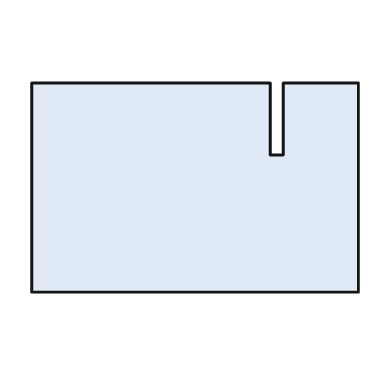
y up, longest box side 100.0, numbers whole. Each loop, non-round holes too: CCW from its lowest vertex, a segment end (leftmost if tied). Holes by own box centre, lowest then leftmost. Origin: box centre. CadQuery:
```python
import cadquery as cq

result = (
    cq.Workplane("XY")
    .moveTo(-50.0, -32.0)
    .lineTo(50.0, -32.0)
    .lineTo(50.0, 32.0)
    .lineTo(27.0, 32.0)
    .lineTo(27.0, 10.0)
    .lineTo(23.0, 10.0)
    .lineTo(23.0, 32.0)
    .lineTo(-50.0, 32.0)
    .close()
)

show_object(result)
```